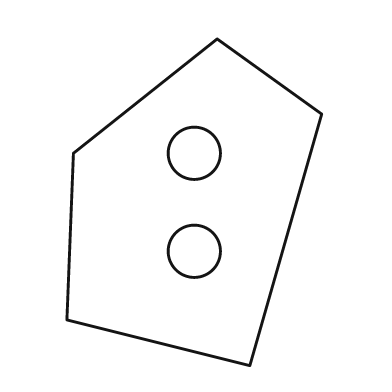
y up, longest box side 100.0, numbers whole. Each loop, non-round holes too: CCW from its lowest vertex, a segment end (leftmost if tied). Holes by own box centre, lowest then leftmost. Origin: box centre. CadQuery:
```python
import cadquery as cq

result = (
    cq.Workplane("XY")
    .moveTo(17.0, -50.0)
    .lineTo(39.0, 27.0)
    .lineTo(7.0, 50.0)
    .lineTo(-37.0, 15.0)
    .lineTo(-39.0, -36.0)
    .close()
    .moveTo(0.0, -15.0)
    .circle(8.0)
    .moveTo(0.0, 15.0)
    .circle(8.0)
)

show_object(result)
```